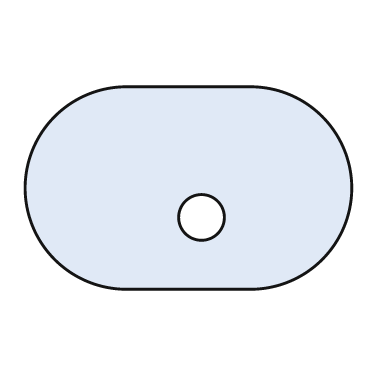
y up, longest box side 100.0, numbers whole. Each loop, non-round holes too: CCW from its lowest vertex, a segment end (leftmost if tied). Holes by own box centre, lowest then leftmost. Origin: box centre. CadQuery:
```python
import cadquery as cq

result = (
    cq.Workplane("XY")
    .moveTo(-19.0, -31.0)
    .lineTo(19.0, -31.0)
    .threePointArc((50.0, 0.0), (19.0, 31.0))
    .lineTo(-19.0, 31.0)
    .threePointArc((-50.0, 0.0), (-19.0, -31.0))
    .close()
    .moveTo(4.0, -9.0)
    .circle(7.0)
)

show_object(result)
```